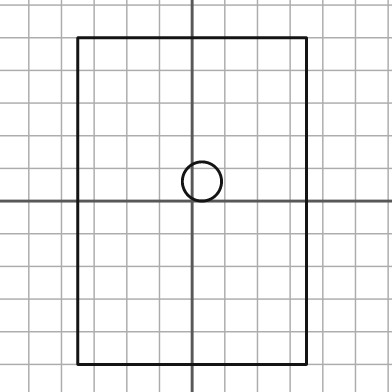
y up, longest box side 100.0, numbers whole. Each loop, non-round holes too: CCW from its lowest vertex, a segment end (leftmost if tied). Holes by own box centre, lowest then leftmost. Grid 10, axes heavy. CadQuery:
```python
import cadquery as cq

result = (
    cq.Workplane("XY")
    .moveTo(-35.0, -50.0)
    .lineTo(35.0, -50.0)
    .lineTo(35.0, 50.0)
    .lineTo(-35.0, 50.0)
    .close()
    .moveTo(3.0, 6.0)
    .circle(6.0)
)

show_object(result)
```